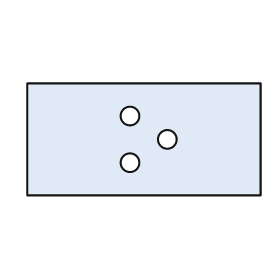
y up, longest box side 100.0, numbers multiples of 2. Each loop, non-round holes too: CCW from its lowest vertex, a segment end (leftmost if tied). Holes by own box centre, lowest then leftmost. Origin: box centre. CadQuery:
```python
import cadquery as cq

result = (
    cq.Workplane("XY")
    .moveTo(-50.0, -24.0)
    .lineTo(50.0, -24.0)
    .lineTo(50.0, 24.0)
    .lineTo(-50.0, 24.0)
    .close()
    .moveTo(-6.0, -10.0)
    .circle(4.0)
    .moveTo(10.0, 0.0)
    .circle(4.0)
    .moveTo(-6.0, 10.0)
    .circle(4.0)
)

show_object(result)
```